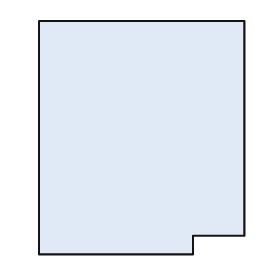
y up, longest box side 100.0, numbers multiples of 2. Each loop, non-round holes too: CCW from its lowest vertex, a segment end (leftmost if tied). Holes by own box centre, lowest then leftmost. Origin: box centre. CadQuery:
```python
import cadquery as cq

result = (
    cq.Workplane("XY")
    .moveTo(-44.0, -50.0)
    .lineTo(22.0, -50.0)
    .lineTo(22.0, -42.0)
    .lineTo(44.0, -42.0)
    .lineTo(44.0, 50.0)
    .lineTo(-44.0, 50.0)
    .close()
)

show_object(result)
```